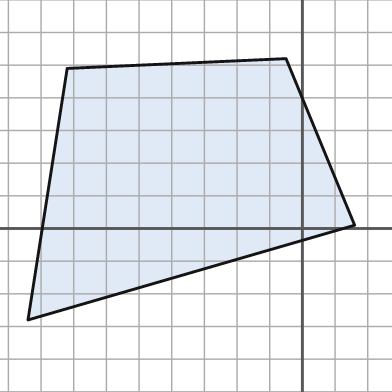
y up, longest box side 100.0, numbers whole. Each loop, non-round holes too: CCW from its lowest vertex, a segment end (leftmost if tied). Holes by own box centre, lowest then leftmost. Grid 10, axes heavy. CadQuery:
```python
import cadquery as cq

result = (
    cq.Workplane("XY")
    .moveTo(-84.0, -28.0)
    .lineTo(16.0, 1.0)
    .lineTo(-5.0, 52.0)
    .lineTo(-72.0, 49.0)
    .close()
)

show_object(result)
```